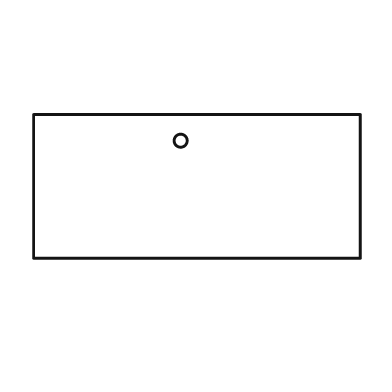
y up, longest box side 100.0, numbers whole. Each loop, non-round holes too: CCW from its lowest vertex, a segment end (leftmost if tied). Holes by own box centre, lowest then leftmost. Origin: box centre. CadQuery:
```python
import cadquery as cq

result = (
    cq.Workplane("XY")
    .moveTo(-50.0, -22.0)
    .lineTo(50.0, -22.0)
    .lineTo(50.0, 22.0)
    .lineTo(-50.0, 22.0)
    .close()
    .moveTo(-5.0, 14.0)
    .circle(2.0)
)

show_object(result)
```